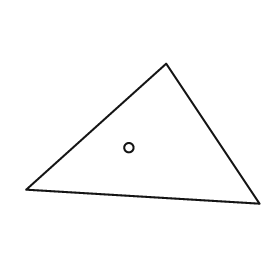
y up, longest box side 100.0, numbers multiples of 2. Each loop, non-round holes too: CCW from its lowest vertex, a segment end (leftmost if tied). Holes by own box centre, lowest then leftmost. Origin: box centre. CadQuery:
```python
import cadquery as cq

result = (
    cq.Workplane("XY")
    .moveTo(50.0, -30.0)
    .lineTo(10.0, 30.0)
    .lineTo(-50.0, -24.0)
    .close()
    .moveTo(-6.0, -6.0)
    .circle(2.0)
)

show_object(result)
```